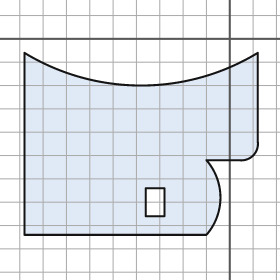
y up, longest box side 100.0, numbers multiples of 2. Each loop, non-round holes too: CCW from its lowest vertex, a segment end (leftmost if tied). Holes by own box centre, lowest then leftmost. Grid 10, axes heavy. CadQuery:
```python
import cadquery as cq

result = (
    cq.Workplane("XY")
    .moveTo(-88.0, -84.0)
    .lineTo(-10.0, -84.0)
    .threePointArc((-4.0, -68.0), (-10.0, -52.0))
    .lineTo(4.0, -52.0)
    .threePointArc((10.0, -50.0), (12.0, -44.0))
    .lineTo(12.0, -6.0)
    .threePointArc((-38.0, -20.0), (-88.0, -6.0))
    .close()
    .moveTo(-36.0, -76.0)
    .lineTo(-28.0, -76.0)
    .lineTo(-28.0, -64.0)
    .lineTo(-36.0, -64.0)
    .close()
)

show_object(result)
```